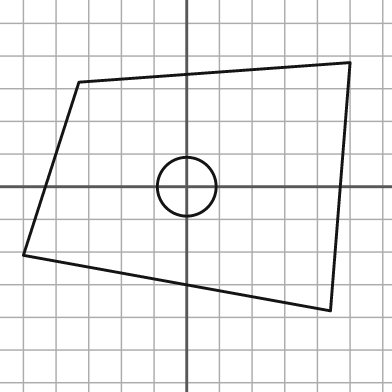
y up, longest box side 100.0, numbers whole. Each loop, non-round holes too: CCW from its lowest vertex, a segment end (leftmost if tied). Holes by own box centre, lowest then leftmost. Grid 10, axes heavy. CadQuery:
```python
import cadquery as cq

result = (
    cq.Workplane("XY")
    .moveTo(44.0, -38.0)
    .lineTo(50.0, 38.0)
    .lineTo(-33.0, 32.0)
    .lineTo(-50.0, -21.0)
    .close()
    .moveTo(0.0, 0.0)
    .circle(9.0)
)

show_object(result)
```